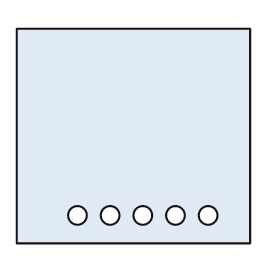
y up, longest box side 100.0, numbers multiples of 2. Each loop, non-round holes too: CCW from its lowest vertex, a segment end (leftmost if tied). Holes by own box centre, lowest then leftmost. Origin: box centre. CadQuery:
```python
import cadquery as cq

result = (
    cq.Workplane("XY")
    .moveTo(-50.0, -46.0)
    .lineTo(50.0, -46.0)
    .lineTo(50.0, 46.0)
    .lineTo(-50.0, 46.0)
    .close()
    .moveTo(-24.0, -34.0)
    .circle(4.0)
    .moveTo(-10.0, -34.0)
    .circle(4.0)
    .moveTo(4.0, -34.0)
    .circle(4.0)
    .moveTo(18.0, -34.0)
    .circle(4.0)
    .moveTo(32.0, -34.0)
    .circle(4.0)
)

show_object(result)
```